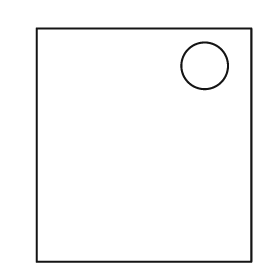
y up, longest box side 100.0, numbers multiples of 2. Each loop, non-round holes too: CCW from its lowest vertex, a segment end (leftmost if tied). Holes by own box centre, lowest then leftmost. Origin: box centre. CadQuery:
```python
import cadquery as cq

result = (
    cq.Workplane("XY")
    .moveTo(-46.0, -50.0)
    .lineTo(46.0, -50.0)
    .lineTo(46.0, 50.0)
    .lineTo(-46.0, 50.0)
    .close()
    .moveTo(26.0, 34.0)
    .circle(10.0)
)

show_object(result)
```